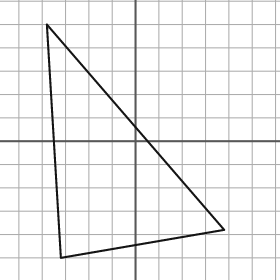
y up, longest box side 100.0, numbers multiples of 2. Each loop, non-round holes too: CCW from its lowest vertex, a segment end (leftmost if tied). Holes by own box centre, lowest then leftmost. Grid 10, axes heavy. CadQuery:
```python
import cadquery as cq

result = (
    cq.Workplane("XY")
    .moveTo(-32.0, -50.0)
    .lineTo(38.0, -38.0)
    .lineTo(-38.0, 50.0)
    .close()
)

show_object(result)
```